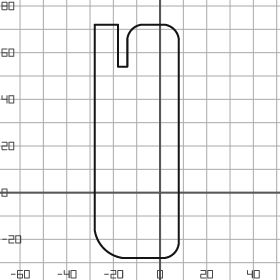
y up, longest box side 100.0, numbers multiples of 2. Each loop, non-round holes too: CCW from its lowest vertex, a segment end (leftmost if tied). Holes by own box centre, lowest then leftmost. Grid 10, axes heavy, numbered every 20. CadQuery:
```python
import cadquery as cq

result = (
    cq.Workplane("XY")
    .moveTo(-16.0, -28.0)
    .lineTo(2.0, -28.0)
    .threePointArc((6.0, -26.0), (8.0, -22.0))
    .lineTo(8.0, 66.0)
    .threePointArc((6.0, 70.0), (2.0, 72.0))
    .lineTo(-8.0, 72.0)
    .threePointArc((-12.0, 70.0), (-14.0, 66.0))
    .lineTo(-14.0, 54.0)
    .lineTo(-18.0, 54.0)
    .lineTo(-18.0, 72.0)
    .lineTo(-28.0, 72.0)
    .lineTo(-28.0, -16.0)
    .threePointArc((-24.0, -24.0), (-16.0, -28.0))
    .close()
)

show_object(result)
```